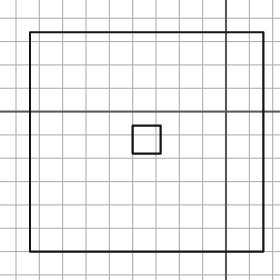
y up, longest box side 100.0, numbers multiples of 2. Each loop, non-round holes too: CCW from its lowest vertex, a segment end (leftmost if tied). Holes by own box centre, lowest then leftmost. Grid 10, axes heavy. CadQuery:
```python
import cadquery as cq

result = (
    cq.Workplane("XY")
    .moveTo(-84.0, -60.0)
    .lineTo(16.0, -60.0)
    .lineTo(16.0, 34.0)
    .lineTo(-84.0, 34.0)
    .close()
    .moveTo(-40.0, -18.0)
    .lineTo(-28.0, -18.0)
    .lineTo(-28.0, -6.0)
    .lineTo(-40.0, -6.0)
    .close()
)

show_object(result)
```